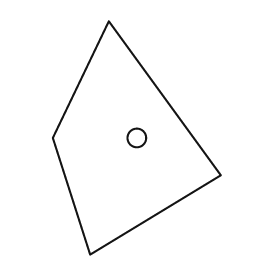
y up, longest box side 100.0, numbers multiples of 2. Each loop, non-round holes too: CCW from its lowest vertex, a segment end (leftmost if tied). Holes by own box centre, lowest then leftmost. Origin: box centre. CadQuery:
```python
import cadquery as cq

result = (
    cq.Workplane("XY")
    .moveTo(-20.0, -50.0)
    .lineTo(36.0, -16.0)
    .lineTo(-12.0, 50.0)
    .lineTo(-36.0, 0.0)
    .close()
    .moveTo(0.0, 0.0)
    .circle(4.0)
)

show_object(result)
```